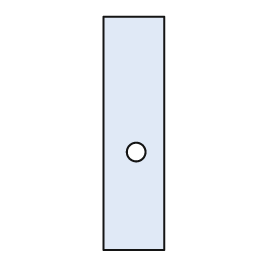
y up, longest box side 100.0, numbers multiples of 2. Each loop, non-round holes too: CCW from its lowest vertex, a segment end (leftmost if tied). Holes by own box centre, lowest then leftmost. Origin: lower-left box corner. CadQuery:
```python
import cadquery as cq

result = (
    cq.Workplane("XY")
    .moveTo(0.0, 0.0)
    .lineTo(26.0, 0.0)
    .lineTo(26.0, 100.0)
    .lineTo(0.0, 100.0)
    .close()
    .moveTo(14.0, 42.0)
    .circle(4.0)
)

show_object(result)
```